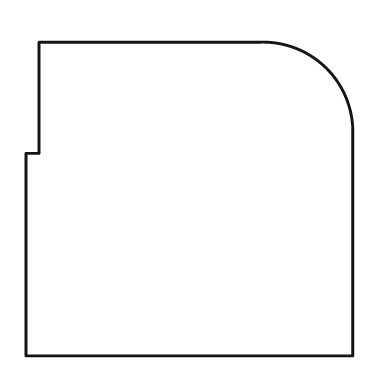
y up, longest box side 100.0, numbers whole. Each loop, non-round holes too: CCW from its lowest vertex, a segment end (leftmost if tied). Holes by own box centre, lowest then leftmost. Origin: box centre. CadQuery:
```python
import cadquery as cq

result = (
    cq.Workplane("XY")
    .moveTo(-50.0, -48.0)
    .lineTo(50.0, -48.0)
    .lineTo(50.0, 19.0)
    .threePointArc((42.0, 40.0), (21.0, 48.0))
    .lineTo(-46.0, 48.0)
    .lineTo(-46.0, 14.0)
    .lineTo(-50.0, 14.0)
    .close()
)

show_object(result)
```